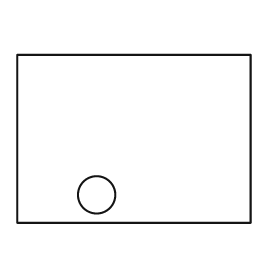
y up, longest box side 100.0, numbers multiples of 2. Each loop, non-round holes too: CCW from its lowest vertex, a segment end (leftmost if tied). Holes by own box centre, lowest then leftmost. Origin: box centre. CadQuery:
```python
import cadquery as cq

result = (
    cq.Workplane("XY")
    .moveTo(-50.0, -36.0)
    .lineTo(50.0, -36.0)
    .lineTo(50.0, 36.0)
    .lineTo(-50.0, 36.0)
    .close()
    .moveTo(-16.0, -24.0)
    .circle(8.0)
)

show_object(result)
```